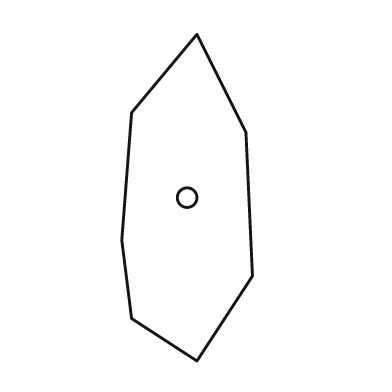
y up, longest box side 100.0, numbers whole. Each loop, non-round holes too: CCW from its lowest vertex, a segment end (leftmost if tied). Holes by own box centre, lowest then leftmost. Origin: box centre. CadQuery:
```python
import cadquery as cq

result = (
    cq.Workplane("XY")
    .moveTo(3.0, -50.0)
    .lineTo(20.0, -24.0)
    .lineTo(18.0, 20.0)
    .lineTo(3.0, 50.0)
    .lineTo(-17.0, 26.0)
    .lineTo(-20.0, -13.0)
    .lineTo(-17.0, -37.0)
    .close()
    .moveTo(0.0, 0.0)
    .circle(3.0)
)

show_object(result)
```